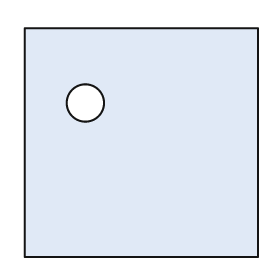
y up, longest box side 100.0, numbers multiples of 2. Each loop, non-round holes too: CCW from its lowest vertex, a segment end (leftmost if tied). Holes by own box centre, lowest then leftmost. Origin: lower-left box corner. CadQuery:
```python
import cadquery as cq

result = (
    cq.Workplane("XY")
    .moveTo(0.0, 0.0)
    .lineTo(100.0, 0.0)
    .lineTo(100.0, 98.0)
    .lineTo(0.0, 98.0)
    .close()
    .moveTo(26.0, 66.0)
    .circle(8.0)
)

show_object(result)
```